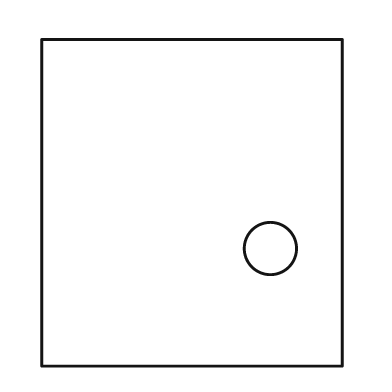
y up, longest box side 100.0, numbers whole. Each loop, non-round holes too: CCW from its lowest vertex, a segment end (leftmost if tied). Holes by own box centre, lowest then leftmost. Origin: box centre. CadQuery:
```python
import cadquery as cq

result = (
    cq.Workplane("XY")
    .moveTo(-46.0, -50.0)
    .lineTo(46.0, -50.0)
    .lineTo(46.0, 50.0)
    .lineTo(-46.0, 50.0)
    .close()
    .moveTo(24.0, -14.0)
    .circle(8.0)
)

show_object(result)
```